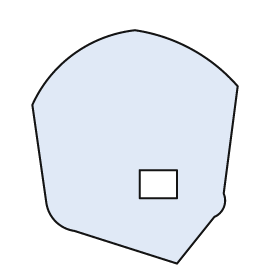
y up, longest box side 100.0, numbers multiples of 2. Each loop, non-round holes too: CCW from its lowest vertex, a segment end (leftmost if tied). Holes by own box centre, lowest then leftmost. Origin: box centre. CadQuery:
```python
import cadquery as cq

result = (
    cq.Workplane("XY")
    .moveTo(18.0, -50.0)
    .lineTo(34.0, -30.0)
    .threePointArc((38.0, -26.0), (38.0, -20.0))
    .lineTo(44.0, 26.0)
    .threePointArc((24.0, 42.0), (0.0, 50.0))
    .threePointArc((-26.0, 40.0), (-44.0, 18.0))
    .lineTo(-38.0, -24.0)
    .threePointArc((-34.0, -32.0), (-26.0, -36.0))
    .close()
    .moveTo(2.0, -22.0)
    .lineTo(18.0, -22.0)
    .lineTo(18.0, -10.0)
    .lineTo(2.0, -10.0)
    .close()
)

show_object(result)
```